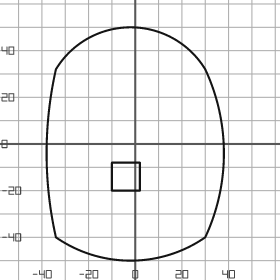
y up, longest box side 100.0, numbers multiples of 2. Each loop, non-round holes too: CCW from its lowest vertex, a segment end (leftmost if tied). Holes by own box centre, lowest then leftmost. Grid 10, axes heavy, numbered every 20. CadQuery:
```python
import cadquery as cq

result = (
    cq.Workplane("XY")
    .moveTo(-34.0, -40.0)
    .threePointArc((-2.0, -50.0), (30.0, -40.0))
    .threePointArc((38.0, -4.0), (30.0, 32.0))
    .threePointArc((-2.0, 50.0), (-34.0, 32.0))
    .threePointArc((-38.0, -4.0), (-34.0, -40.0))
    .close()
    .moveTo(-10.0, -20.0)
    .lineTo(2.0, -20.0)
    .lineTo(2.0, -8.0)
    .lineTo(-10.0, -8.0)
    .close()
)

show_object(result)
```